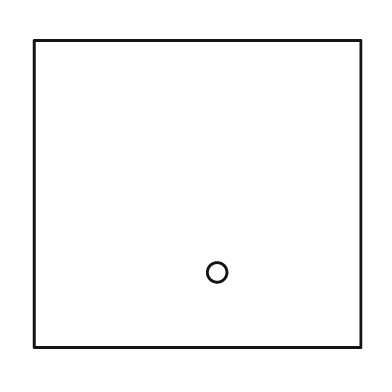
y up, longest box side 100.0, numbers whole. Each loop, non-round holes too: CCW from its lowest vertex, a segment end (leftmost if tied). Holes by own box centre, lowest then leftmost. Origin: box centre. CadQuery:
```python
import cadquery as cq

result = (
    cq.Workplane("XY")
    .moveTo(-50.0, -47.0)
    .lineTo(50.0, -47.0)
    .lineTo(50.0, 47.0)
    .lineTo(-50.0, 47.0)
    .close()
    .moveTo(6.0, -24.0)
    .circle(3.0)
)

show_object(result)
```